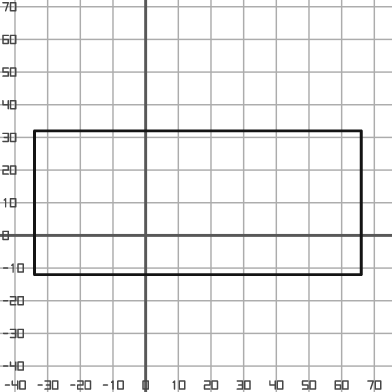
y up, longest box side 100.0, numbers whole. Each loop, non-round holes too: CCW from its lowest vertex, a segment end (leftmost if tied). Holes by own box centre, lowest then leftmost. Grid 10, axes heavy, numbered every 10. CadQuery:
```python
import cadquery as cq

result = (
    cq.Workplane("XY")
    .moveTo(-34.0, -12.0)
    .lineTo(66.0, -12.0)
    .lineTo(66.0, 32.0)
    .lineTo(-34.0, 32.0)
    .close()
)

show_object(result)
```